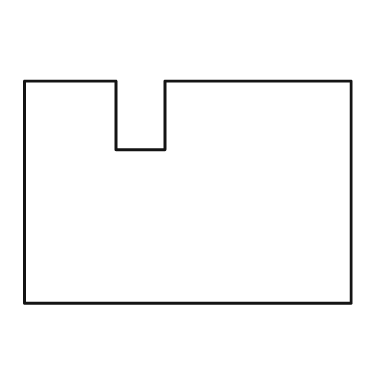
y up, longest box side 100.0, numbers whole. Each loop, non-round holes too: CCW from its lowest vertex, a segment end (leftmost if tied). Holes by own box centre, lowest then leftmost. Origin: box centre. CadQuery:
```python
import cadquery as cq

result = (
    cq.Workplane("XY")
    .moveTo(-50.0, -34.0)
    .lineTo(50.0, -34.0)
    .lineTo(50.0, 34.0)
    .lineTo(-7.0, 34.0)
    .lineTo(-7.0, 13.0)
    .lineTo(-22.0, 13.0)
    .lineTo(-22.0, 34.0)
    .lineTo(-50.0, 34.0)
    .close()
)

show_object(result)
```